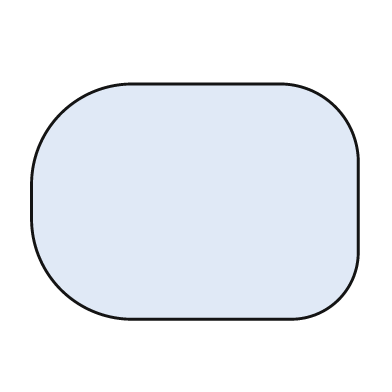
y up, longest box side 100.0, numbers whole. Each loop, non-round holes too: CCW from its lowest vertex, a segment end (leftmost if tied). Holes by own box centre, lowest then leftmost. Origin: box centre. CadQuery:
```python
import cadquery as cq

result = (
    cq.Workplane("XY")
    .moveTo(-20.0, -36.0)
    .lineTo(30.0, -36.0)
    .threePointArc((44.0, -30.0), (50.0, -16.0))
    .lineTo(50.0, 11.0)
    .threePointArc((43.0, 29.0), (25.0, 36.0))
    .lineTo(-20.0, 36.0)
    .threePointArc((-41.0, 27.0), (-50.0, 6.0))
    .lineTo(-50.0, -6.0)
    .threePointArc((-41.0, -27.0), (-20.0, -36.0))
    .close()
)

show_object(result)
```